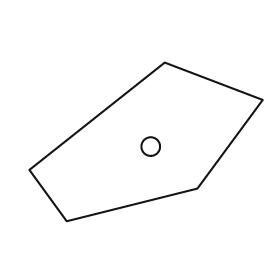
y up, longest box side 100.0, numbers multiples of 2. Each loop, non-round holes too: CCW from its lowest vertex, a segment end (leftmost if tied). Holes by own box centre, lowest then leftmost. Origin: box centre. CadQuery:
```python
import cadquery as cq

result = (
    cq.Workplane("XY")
    .moveTo(-34.0, -34.0)
    .lineTo(22.0, -20.0)
    .lineTo(50.0, 18.0)
    .lineTo(8.0, 34.0)
    .lineTo(-50.0, -12.0)
    .close()
    .moveTo(2.0, -2.0)
    .circle(4.0)
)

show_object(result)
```